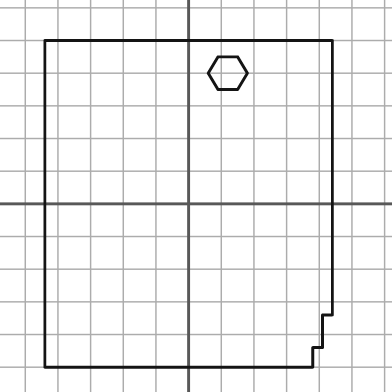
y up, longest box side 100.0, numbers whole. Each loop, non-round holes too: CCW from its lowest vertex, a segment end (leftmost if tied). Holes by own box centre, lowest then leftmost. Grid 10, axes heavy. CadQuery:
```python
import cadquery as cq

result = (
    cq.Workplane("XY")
    .moveTo(-44.0, -50.0)
    .lineTo(38.0, -50.0)
    .lineTo(38.0, -44.0)
    .lineTo(41.0, -44.0)
    .lineTo(41.0, -34.0)
    .lineTo(44.0, -34.0)
    .lineTo(44.0, 50.0)
    .lineTo(-44.0, 50.0)
    .close()
    .moveTo(9.0, 35.0)
    .lineTo(15.0, 35.0)
    .lineTo(18.0, 40.0)
    .lineTo(15.0, 45.0)
    .lineTo(9.0, 45.0)
    .lineTo(6.0, 40.0)
    .close()
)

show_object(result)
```